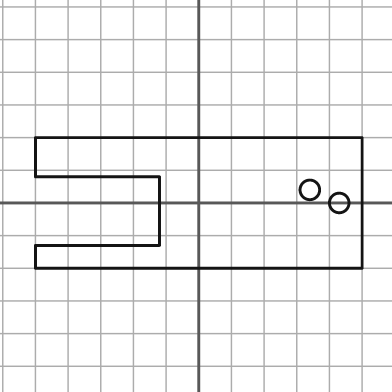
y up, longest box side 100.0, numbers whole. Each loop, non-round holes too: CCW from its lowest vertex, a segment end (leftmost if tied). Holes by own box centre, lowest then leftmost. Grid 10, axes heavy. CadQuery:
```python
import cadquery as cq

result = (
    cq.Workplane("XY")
    .moveTo(-50.0, -20.0)
    .lineTo(50.0, -20.0)
    .lineTo(50.0, 20.0)
    .lineTo(-50.0, 20.0)
    .lineTo(-50.0, 8.0)
    .lineTo(-12.0, 8.0)
    .lineTo(-12.0, -13.0)
    .lineTo(-50.0, -13.0)
    .close()
    .moveTo(43.0, 0.0)
    .circle(3.0)
    .moveTo(34.0, 4.0)
    .circle(3.0)
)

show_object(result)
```